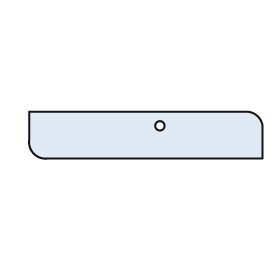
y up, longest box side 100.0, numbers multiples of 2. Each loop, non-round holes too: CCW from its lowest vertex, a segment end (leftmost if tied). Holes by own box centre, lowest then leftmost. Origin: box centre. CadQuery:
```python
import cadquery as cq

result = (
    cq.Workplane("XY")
    .moveTo(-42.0, -10.0)
    .lineTo(50.0, -10.0)
    .lineTo(50.0, 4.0)
    .threePointArc((48.0, 8.0), (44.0, 10.0))
    .lineTo(-50.0, 10.0)
    .lineTo(-50.0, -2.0)
    .threePointArc((-48.0, -8.0), (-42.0, -10.0))
    .close()
    .moveTo(6.0, 4.0)
    .circle(2.0)
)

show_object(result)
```